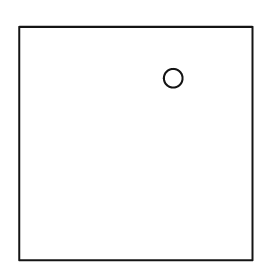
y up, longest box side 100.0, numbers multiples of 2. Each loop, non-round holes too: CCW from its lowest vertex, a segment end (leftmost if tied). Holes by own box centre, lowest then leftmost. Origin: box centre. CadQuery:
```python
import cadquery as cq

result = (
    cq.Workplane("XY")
    .moveTo(-50.0, -50.0)
    .lineTo(50.0, -50.0)
    .lineTo(50.0, 50.0)
    .lineTo(-50.0, 50.0)
    .close()
    .moveTo(16.0, 28.0)
    .circle(4.0)
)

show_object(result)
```